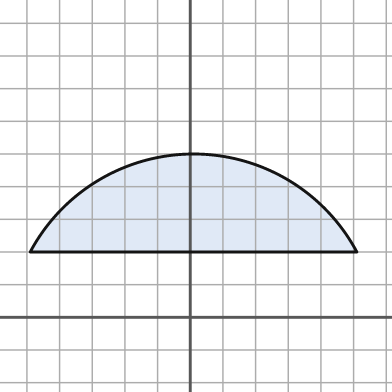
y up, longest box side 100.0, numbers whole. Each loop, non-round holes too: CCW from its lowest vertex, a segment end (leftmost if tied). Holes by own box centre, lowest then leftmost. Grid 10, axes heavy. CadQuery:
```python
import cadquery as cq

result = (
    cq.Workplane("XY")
    .moveTo(-49.0, 20.0)
    .lineTo(51.0, 20.0)
    .threePointArc((1.0, 50.0), (-49.0, 20.0))
    .close()
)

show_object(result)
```